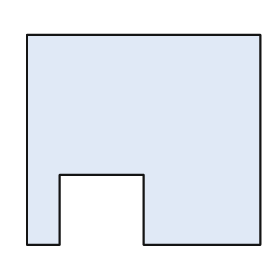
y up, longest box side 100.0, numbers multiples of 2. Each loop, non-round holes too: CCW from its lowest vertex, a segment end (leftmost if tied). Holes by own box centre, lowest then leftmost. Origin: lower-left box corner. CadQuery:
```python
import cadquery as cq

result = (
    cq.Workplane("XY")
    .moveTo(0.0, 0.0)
    .lineTo(14.0, 0.0)
    .lineTo(14.0, 30.0)
    .lineTo(50.0, 30.0)
    .lineTo(50.0, 0.0)
    .lineTo(100.0, 0.0)
    .lineTo(100.0, 90.0)
    .lineTo(0.0, 90.0)
    .close()
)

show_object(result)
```